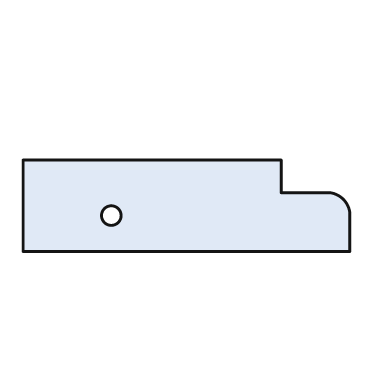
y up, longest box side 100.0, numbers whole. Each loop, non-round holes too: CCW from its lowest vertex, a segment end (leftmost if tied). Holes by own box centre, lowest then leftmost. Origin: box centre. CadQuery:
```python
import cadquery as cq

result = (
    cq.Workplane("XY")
    .moveTo(-50.0, -14.0)
    .lineTo(50.0, -14.0)
    .lineTo(50.0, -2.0)
    .threePointArc((48.0, 2.0), (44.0, 4.0))
    .lineTo(29.0, 4.0)
    .lineTo(29.0, 14.0)
    .lineTo(-50.0, 14.0)
    .close()
    .moveTo(-23.0, -3.0)
    .circle(3.0)
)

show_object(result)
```